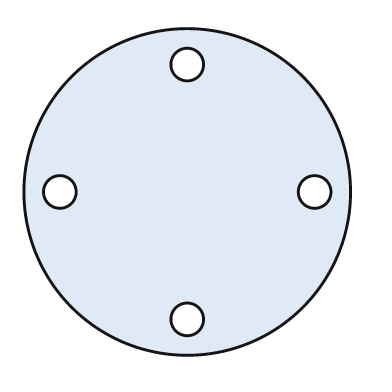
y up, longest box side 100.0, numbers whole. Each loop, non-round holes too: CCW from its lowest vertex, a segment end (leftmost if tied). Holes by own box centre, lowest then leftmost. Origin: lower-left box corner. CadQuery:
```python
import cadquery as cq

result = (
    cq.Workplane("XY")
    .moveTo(50.0, 50.0)
    .circle(50.0)
    .moveTo(50.0, 11.0)
    .circle(5.0)
    .moveTo(11.0, 50.0)
    .circle(5.0)
    .moveTo(89.0, 50.0)
    .circle(5.0)
    .moveTo(50.0, 89.0)
    .circle(5.0)
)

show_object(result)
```